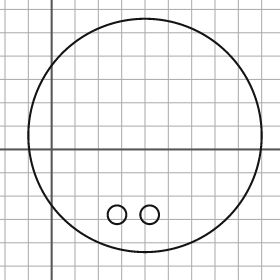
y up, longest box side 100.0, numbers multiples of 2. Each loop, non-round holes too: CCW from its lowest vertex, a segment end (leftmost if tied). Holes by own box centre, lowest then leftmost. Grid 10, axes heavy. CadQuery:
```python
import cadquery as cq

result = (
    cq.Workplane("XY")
    .moveTo(40.0, 6.0)
    .circle(50.0)
    .moveTo(28.0, -28.0)
    .circle(4.0)
    .moveTo(42.0, -28.0)
    .circle(4.0)
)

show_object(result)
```